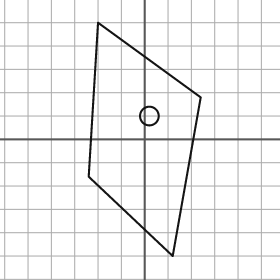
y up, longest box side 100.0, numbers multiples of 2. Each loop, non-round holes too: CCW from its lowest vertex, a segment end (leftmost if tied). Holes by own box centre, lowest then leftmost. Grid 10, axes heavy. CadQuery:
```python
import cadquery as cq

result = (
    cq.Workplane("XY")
    .moveTo(12.0, -50.0)
    .lineTo(24.0, 18.0)
    .lineTo(-20.0, 50.0)
    .lineTo(-24.0, -16.0)
    .close()
    .moveTo(2.0, 10.0)
    .circle(4.0)
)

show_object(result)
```